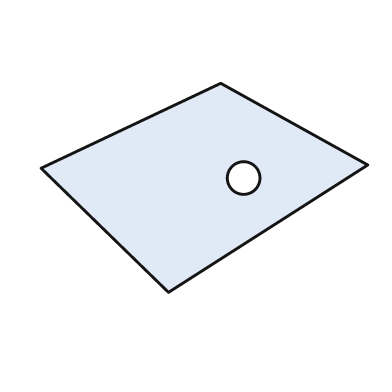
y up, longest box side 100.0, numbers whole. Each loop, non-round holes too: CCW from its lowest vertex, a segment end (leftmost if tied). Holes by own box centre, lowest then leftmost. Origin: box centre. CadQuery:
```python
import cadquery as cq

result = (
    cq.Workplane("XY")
    .moveTo(-11.0, -32.0)
    .lineTo(50.0, 7.0)
    .lineTo(5.0, 32.0)
    .lineTo(-50.0, 6.0)
    .close()
    .moveTo(12.0, 3.0)
    .circle(5.0)
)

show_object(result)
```